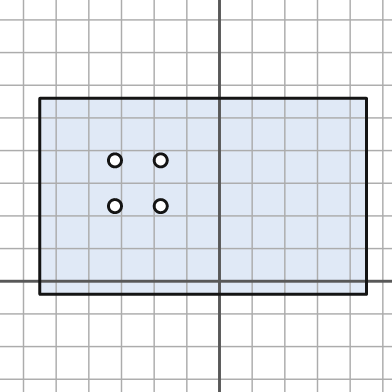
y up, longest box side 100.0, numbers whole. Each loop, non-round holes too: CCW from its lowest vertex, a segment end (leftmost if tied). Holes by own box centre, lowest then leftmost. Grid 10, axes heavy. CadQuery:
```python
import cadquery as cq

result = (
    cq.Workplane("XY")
    .moveTo(-55.0, -4.0)
    .lineTo(45.0, -4.0)
    .lineTo(45.0, 56.0)
    .lineTo(-55.0, 56.0)
    .close()
    .moveTo(-32.0, 23.0)
    .circle(2.0)
    .moveTo(-18.0, 23.0)
    .circle(2.0)
    .moveTo(-32.0, 37.0)
    .circle(2.0)
    .moveTo(-18.0, 37.0)
    .circle(2.0)
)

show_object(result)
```